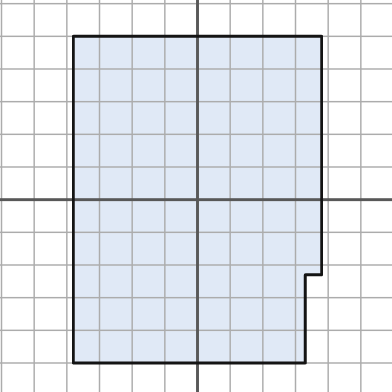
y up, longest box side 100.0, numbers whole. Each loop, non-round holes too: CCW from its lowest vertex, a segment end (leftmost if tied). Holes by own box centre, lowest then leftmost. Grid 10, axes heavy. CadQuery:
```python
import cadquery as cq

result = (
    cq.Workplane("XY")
    .moveTo(-38.0, -50.0)
    .lineTo(33.0, -50.0)
    .lineTo(33.0, -23.0)
    .lineTo(38.0, -23.0)
    .lineTo(38.0, 50.0)
    .lineTo(-38.0, 50.0)
    .close()
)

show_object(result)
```